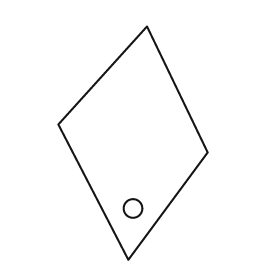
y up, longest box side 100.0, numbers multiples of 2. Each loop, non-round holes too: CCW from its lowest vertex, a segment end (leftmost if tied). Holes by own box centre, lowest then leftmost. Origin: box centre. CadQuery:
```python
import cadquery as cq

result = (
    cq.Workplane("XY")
    .moveTo(-2.0, -50.0)
    .lineTo(32.0, -4.0)
    .lineTo(6.0, 50.0)
    .lineTo(-32.0, 8.0)
    .close()
    .moveTo(0.0, -28.0)
    .circle(4.0)
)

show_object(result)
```